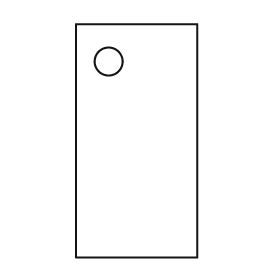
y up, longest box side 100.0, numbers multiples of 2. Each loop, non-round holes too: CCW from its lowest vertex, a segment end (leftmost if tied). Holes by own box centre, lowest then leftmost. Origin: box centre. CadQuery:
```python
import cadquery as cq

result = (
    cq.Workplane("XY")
    .moveTo(-26.0, -50.0)
    .lineTo(26.0, -50.0)
    .lineTo(26.0, 50.0)
    .lineTo(-26.0, 50.0)
    .close()
    .moveTo(-12.0, 34.0)
    .circle(6.0)
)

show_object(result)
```